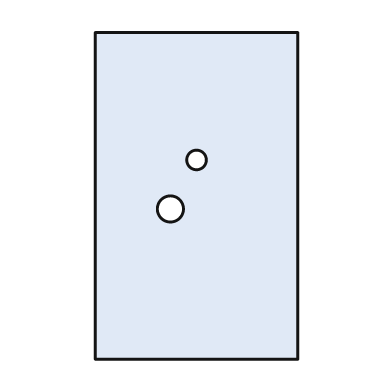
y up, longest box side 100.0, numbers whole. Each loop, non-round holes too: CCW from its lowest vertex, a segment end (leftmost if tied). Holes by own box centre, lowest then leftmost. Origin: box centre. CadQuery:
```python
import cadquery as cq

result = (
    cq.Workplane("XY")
    .moveTo(-31.0, -50.0)
    .lineTo(31.0, -50.0)
    .lineTo(31.0, 50.0)
    .lineTo(-31.0, 50.0)
    .close()
    .moveTo(-8.0, -4.0)
    .circle(4.0)
    .moveTo(0.0, 11.0)
    .circle(3.0)
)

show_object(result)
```